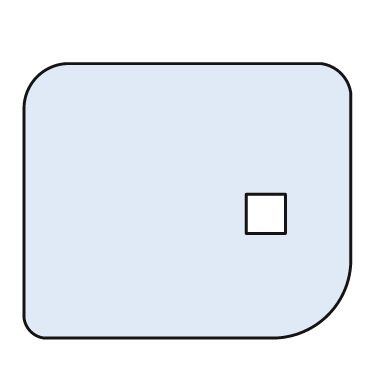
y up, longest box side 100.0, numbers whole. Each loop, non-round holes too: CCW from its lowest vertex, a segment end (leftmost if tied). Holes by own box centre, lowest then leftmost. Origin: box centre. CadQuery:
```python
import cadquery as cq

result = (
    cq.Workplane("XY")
    .moveTo(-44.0, -42.0)
    .lineTo(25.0, -42.0)
    .threePointArc((43.0, -35.0), (50.0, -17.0))
    .lineTo(50.0, 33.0)
    .threePointArc((47.0, 39.0), (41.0, 42.0))
    .lineTo(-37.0, 42.0)
    .threePointArc((-46.0, 38.0), (-50.0, 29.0))
    .lineTo(-50.0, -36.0)
    .threePointArc((-48.0, -40.0), (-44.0, -42.0))
    .close()
    .moveTo(18.0, -10.0)
    .lineTo(30.0, -10.0)
    .lineTo(30.0, 2.0)
    .lineTo(18.0, 2.0)
    .close()
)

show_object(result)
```